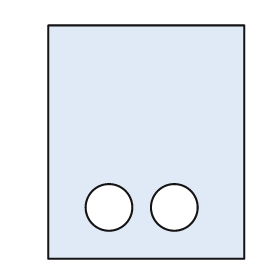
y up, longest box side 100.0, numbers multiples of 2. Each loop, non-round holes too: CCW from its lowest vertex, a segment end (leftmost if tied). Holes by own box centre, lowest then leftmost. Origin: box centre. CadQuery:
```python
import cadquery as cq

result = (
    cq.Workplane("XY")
    .moveTo(-42.0, -50.0)
    .lineTo(42.0, -50.0)
    .lineTo(42.0, 50.0)
    .lineTo(-42.0, 50.0)
    .close()
    .moveTo(-16.0, -28.0)
    .circle(10.0)
    .moveTo(12.0, -28.0)
    .circle(10.0)
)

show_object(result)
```